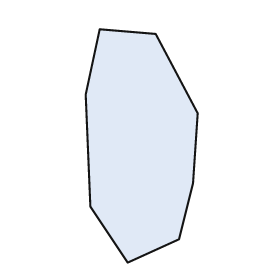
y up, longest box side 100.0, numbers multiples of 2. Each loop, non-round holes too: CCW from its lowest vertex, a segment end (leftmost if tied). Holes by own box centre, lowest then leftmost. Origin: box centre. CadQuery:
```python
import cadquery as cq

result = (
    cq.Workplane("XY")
    .moveTo(-6.0, -50.0)
    .lineTo(16.0, -40.0)
    .lineTo(22.0, -16.0)
    .lineTo(24.0, 14.0)
    .lineTo(6.0, 48.0)
    .lineTo(-18.0, 50.0)
    .lineTo(-24.0, 22.0)
    .lineTo(-22.0, -26.0)
    .close()
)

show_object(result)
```